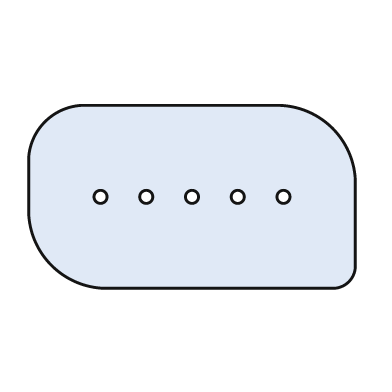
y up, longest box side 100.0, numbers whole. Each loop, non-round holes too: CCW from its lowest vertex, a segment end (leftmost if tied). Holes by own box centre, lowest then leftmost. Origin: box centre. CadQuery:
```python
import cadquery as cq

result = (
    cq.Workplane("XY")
    .moveTo(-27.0, -28.0)
    .lineTo(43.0, -28.0)
    .threePointArc((48.0, -26.0), (50.0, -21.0))
    .lineTo(50.0, 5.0)
    .threePointArc((43.0, 21.0), (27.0, 28.0))
    .lineTo(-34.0, 28.0)
    .threePointArc((-45.0, 23.0), (-50.0, 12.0))
    .lineTo(-50.0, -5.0)
    .threePointArc((-43.0, -21.0), (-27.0, -28.0))
    .close()
    .moveTo(-28.0, 0.0)
    .circle(2.0)
    .moveTo(-14.0, 0.0)
    .circle(2.0)
    .moveTo(0.0, 0.0)
    .circle(2.0)
    .moveTo(14.0, 0.0)
    .circle(2.0)
    .moveTo(28.0, 0.0)
    .circle(2.0)
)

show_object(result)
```